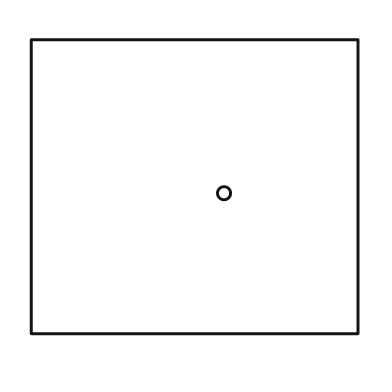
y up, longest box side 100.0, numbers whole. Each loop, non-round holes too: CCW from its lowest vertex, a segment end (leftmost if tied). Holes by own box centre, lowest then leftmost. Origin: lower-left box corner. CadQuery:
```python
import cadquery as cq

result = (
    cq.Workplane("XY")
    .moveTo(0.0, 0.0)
    .lineTo(100.0, 0.0)
    .lineTo(100.0, 90.0)
    .lineTo(0.0, 90.0)
    .close()
    .moveTo(59.0, 43.0)
    .circle(2.0)
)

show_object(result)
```